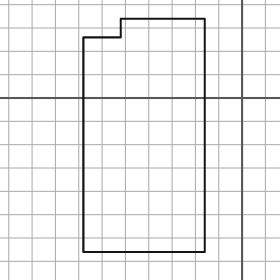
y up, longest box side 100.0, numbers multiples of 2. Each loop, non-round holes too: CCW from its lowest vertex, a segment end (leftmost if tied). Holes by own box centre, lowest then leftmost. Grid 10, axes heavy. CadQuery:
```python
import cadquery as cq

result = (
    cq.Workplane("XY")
    .moveTo(-68.0, -66.0)
    .lineTo(-16.0, -66.0)
    .lineTo(-16.0, 34.0)
    .lineTo(-52.0, 34.0)
    .lineTo(-52.0, 26.0)
    .lineTo(-68.0, 26.0)
    .close()
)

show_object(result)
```